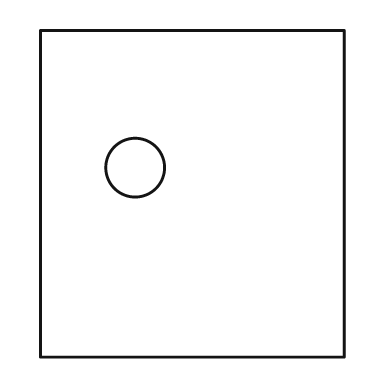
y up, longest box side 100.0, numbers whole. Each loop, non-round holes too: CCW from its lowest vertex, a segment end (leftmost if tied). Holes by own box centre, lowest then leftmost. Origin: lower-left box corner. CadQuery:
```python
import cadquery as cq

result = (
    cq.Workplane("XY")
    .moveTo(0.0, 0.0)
    .lineTo(93.0, 0.0)
    .lineTo(93.0, 100.0)
    .lineTo(0.0, 100.0)
    .close()
    .moveTo(29.0, 58.0)
    .circle(9.0)
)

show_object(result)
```